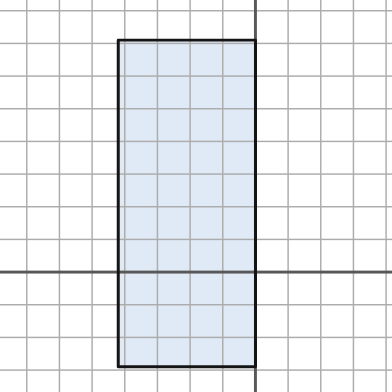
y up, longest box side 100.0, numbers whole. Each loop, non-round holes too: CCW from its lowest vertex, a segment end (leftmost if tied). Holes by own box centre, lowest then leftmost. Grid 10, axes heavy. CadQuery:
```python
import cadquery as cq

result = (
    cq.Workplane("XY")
    .moveTo(-42.0, -29.0)
    .lineTo(0.0, -29.0)
    .lineTo(0.0, 71.0)
    .lineTo(-42.0, 71.0)
    .close()
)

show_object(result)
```